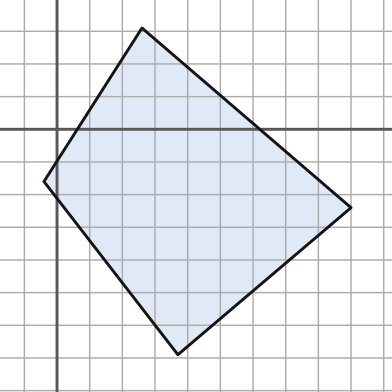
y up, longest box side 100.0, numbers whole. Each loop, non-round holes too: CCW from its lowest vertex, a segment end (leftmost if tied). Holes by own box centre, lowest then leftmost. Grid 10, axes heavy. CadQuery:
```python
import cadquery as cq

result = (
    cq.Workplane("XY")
    .moveTo(37.0, -69.0)
    .lineTo(90.0, -24.0)
    .lineTo(26.0, 31.0)
    .lineTo(-4.0, -16.0)
    .close()
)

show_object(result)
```